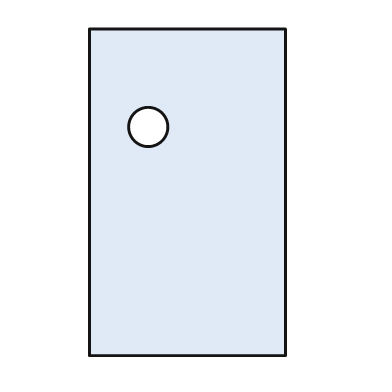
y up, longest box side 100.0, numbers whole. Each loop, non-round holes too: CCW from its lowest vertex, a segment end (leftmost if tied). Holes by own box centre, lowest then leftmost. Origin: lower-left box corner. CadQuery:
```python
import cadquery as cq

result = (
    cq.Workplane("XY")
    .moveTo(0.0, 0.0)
    .lineTo(60.0, 0.0)
    .lineTo(60.0, 100.0)
    .lineTo(0.0, 100.0)
    .close()
    .moveTo(18.0, 70.0)
    .circle(6.0)
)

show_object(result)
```